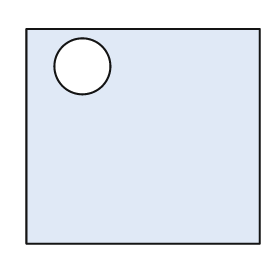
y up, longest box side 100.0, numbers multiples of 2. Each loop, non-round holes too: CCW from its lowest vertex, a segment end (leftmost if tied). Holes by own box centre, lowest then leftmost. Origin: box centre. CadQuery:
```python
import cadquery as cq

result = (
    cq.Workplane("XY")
    .moveTo(-50.0, -46.0)
    .lineTo(50.0, -46.0)
    .lineTo(50.0, 46.0)
    .lineTo(-50.0, 46.0)
    .close()
    .moveTo(-26.0, 30.0)
    .circle(12.0)
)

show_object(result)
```